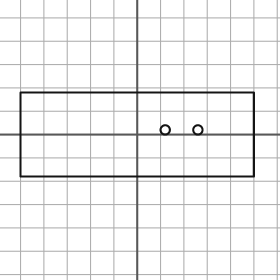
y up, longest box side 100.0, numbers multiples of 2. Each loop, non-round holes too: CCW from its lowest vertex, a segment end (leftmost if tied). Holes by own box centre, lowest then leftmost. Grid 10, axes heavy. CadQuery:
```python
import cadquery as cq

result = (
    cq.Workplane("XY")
    .moveTo(-50.0, -18.0)
    .lineTo(50.0, -18.0)
    .lineTo(50.0, 18.0)
    .lineTo(-50.0, 18.0)
    .close()
    .moveTo(12.0, 2.0)
    .circle(2.0)
    .moveTo(26.0, 2.0)
    .circle(2.0)
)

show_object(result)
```